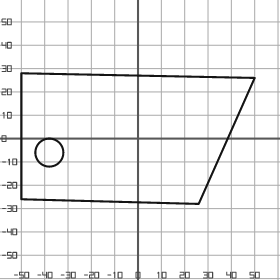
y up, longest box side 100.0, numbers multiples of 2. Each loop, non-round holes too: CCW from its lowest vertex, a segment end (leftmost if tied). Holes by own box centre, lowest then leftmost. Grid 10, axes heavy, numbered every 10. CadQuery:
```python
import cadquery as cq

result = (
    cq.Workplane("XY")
    .moveTo(26.0, -28.0)
    .lineTo(50.0, 26.0)
    .lineTo(-50.0, 28.0)
    .lineTo(-50.0, -26.0)
    .close()
    .moveTo(-38.0, -6.0)
    .circle(6.0)
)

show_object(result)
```